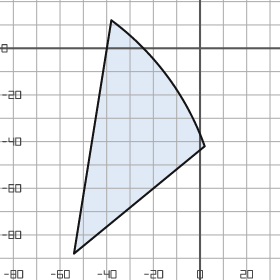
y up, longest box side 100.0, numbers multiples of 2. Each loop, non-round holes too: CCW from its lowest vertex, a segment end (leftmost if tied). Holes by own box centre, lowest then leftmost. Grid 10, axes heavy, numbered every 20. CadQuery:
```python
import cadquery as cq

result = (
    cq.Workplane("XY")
    .moveTo(-54.0, -88.0)
    .lineTo(2.0, -42.0)
    .threePointArc((-14.0, -12.0), (-38.0, 12.0))
    .close()
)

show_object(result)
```